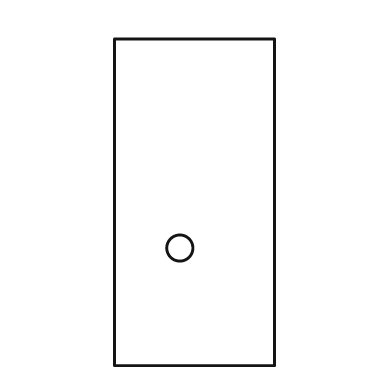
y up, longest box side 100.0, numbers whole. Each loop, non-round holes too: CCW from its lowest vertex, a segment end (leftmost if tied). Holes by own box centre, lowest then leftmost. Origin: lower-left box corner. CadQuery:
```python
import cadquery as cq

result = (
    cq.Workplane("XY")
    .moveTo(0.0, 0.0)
    .lineTo(49.0, 0.0)
    .lineTo(49.0, 100.0)
    .lineTo(0.0, 100.0)
    .close()
    .moveTo(20.0, 36.0)
    .circle(4.0)
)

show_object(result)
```